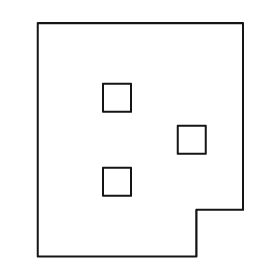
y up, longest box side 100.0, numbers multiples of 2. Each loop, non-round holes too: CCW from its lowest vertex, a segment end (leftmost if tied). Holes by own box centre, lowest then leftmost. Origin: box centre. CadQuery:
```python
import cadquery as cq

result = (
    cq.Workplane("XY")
    .moveTo(-44.0, -50.0)
    .lineTo(24.0, -50.0)
    .lineTo(24.0, -30.0)
    .lineTo(44.0, -30.0)
    .lineTo(44.0, 50.0)
    .lineTo(-44.0, 50.0)
    .close()
    .moveTo(-16.0, -24.0)
    .lineTo(-4.0, -24.0)
    .lineTo(-4.0, -12.0)
    .lineTo(-16.0, -12.0)
    .close()
    .moveTo(16.0, -6.0)
    .lineTo(28.0, -6.0)
    .lineTo(28.0, 6.0)
    .lineTo(16.0, 6.0)
    .close()
    .moveTo(-16.0, 12.0)
    .lineTo(-4.0, 12.0)
    .lineTo(-4.0, 24.0)
    .lineTo(-16.0, 24.0)
    .close()
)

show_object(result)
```